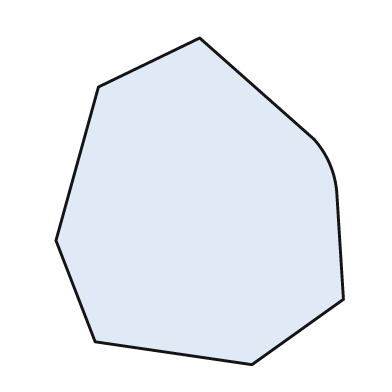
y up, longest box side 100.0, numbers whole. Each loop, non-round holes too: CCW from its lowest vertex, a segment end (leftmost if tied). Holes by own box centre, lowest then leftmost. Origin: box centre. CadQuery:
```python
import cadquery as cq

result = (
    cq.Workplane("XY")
    .moveTo(16.0, -50.0)
    .lineTo(44.0, -30.0)
    .lineTo(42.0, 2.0)
    .threePointArc((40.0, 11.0), (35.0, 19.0))
    .lineTo(0.0, 50.0)
    .lineTo(-31.0, 35.0)
    .lineTo(-44.0, -12.0)
    .lineTo(-32.0, -43.0)
    .close()
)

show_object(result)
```